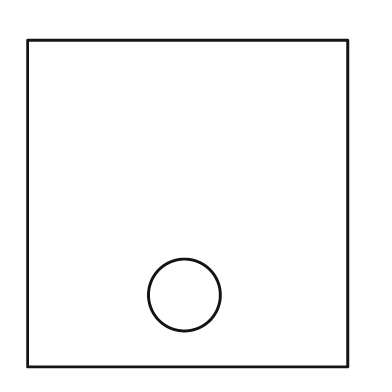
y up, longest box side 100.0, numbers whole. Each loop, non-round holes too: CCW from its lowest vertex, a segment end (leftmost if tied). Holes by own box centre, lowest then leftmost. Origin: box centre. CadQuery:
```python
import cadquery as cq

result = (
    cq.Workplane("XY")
    .moveTo(-49.0, -50.0)
    .lineTo(49.0, -50.0)
    .lineTo(49.0, 50.0)
    .lineTo(-49.0, 50.0)
    .close()
    .moveTo(-1.0, -28.0)
    .circle(11.0)
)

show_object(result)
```